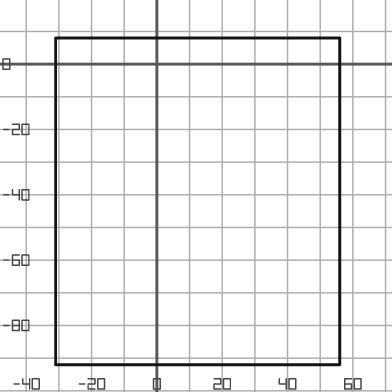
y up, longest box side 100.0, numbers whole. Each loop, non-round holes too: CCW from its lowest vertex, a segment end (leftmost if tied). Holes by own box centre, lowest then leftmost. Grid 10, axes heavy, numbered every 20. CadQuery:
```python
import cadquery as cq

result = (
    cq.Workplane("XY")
    .moveTo(-31.0, -92.0)
    .lineTo(56.0, -92.0)
    .lineTo(56.0, 8.0)
    .lineTo(-31.0, 8.0)
    .close()
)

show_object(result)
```